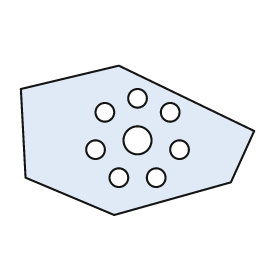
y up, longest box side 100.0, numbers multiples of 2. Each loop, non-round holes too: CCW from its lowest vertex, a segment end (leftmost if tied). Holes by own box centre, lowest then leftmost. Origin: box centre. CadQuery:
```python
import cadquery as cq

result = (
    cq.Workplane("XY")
    .moveTo(-10.0, -32.0)
    .lineTo(40.0, -18.0)
    .lineTo(50.0, 4.0)
    .lineTo(-8.0, 32.0)
    .lineTo(-50.0, 22.0)
    .lineTo(-48.0, -16.0)
    .close()
    .moveTo(-8.0, -16.0)
    .circle(4.0)
    .moveTo(8.0, -16.0)
    .circle(4.0)
    .moveTo(-18.0, -4.0)
    .circle(4.0)
    .moveTo(18.0, -4.0)
    .circle(4.0)
    .moveTo(0.0, 0.0)
    .circle(6.0)
    .moveTo(-14.0, 12.0)
    .circle(4.0)
    .moveTo(14.0, 12.0)
    .circle(4.0)
    .moveTo(0.0, 18.0)
    .circle(4.0)
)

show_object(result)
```